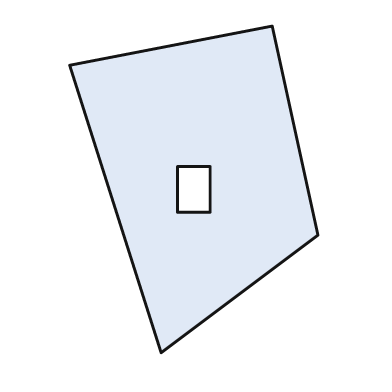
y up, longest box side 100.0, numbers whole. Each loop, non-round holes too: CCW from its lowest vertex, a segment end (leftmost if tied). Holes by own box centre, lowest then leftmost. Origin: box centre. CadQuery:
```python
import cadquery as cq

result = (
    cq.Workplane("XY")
    .moveTo(-10.0, -50.0)
    .lineTo(38.0, -14.0)
    .lineTo(24.0, 50.0)
    .lineTo(-38.0, 38.0)
    .close()
    .moveTo(-5.0, -7.0)
    .lineTo(5.0, -7.0)
    .lineTo(5.0, 7.0)
    .lineTo(-5.0, 7.0)
    .close()
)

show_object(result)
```